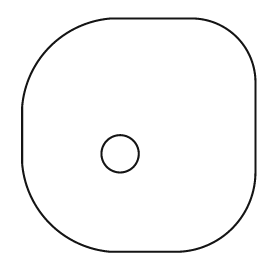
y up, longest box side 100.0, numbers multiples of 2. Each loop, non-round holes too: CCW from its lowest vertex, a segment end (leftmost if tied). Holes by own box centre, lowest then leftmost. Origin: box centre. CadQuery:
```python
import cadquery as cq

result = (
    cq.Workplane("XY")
    .moveTo(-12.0, -50.0)
    .lineTo(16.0, -50.0)
    .threePointArc((40.0, -40.0), (50.0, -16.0))
    .lineTo(50.0, 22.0)
    .threePointArc((42.0, 42.0), (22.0, 50.0))
    .lineTo(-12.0, 50.0)
    .threePointArc((-38.0, 38.0), (-50.0, 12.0))
    .lineTo(-50.0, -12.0)
    .threePointArc((-38.0, -38.0), (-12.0, -50.0))
    .close()
    .moveTo(-8.0, -8.0)
    .circle(8.0)
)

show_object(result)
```